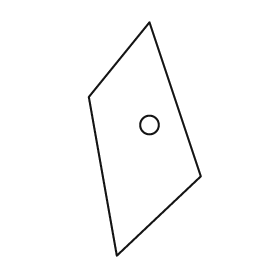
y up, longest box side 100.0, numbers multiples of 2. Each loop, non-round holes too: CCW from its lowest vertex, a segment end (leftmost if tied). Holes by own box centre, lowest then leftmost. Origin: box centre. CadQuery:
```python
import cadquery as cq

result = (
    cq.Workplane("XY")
    .moveTo(-12.0, -50.0)
    .lineTo(24.0, -16.0)
    .lineTo(2.0, 50.0)
    .lineTo(-24.0, 18.0)
    .close()
    .moveTo(2.0, 6.0)
    .circle(4.0)
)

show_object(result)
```